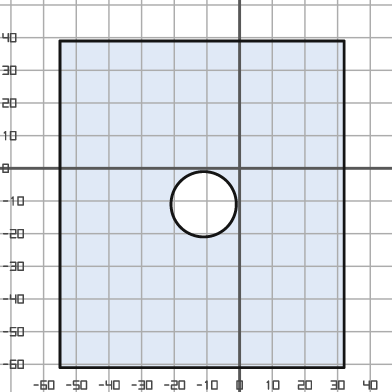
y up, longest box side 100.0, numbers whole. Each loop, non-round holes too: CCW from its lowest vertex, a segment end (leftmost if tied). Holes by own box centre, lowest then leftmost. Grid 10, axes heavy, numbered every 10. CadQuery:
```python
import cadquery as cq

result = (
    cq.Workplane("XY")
    .moveTo(-55.0, -61.0)
    .lineTo(32.0, -61.0)
    .lineTo(32.0, 39.0)
    .lineTo(-55.0, 39.0)
    .close()
    .moveTo(-11.0, -11.0)
    .circle(10.0)
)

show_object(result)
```